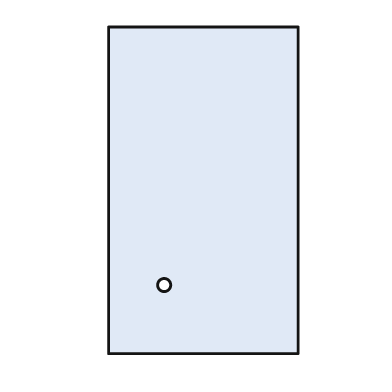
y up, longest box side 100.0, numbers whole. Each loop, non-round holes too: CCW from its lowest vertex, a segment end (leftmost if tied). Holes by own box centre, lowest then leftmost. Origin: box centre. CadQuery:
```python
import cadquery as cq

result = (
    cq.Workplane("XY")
    .moveTo(-29.0, -50.0)
    .lineTo(29.0, -50.0)
    .lineTo(29.0, 50.0)
    .lineTo(-29.0, 50.0)
    .close()
    .moveTo(-12.0, -29.0)
    .circle(2.0)
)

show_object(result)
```